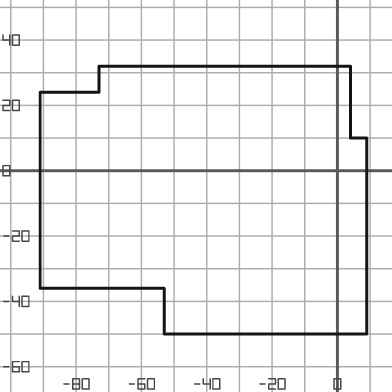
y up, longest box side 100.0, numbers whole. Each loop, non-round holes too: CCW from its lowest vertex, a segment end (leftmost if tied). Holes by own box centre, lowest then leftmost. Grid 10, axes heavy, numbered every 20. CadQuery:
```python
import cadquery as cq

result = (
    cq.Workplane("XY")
    .moveTo(-53.0, -50.0)
    .lineTo(9.0, -50.0)
    .lineTo(9.0, 10.0)
    .lineTo(4.0, 10.0)
    .lineTo(4.0, 32.0)
    .lineTo(-73.0, 32.0)
    .lineTo(-73.0, 24.0)
    .lineTo(-91.0, 24.0)
    .lineTo(-91.0, -36.0)
    .lineTo(-53.0, -36.0)
    .close()
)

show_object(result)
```